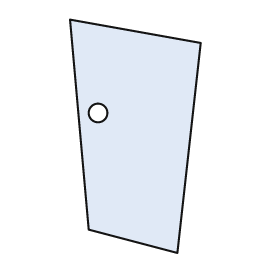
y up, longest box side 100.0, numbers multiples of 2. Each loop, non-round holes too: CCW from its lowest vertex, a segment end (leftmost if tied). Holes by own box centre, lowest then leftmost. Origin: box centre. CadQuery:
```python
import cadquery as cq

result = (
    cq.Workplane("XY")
    .moveTo(18.0, -50.0)
    .lineTo(28.0, 40.0)
    .lineTo(-28.0, 50.0)
    .lineTo(-20.0, -40.0)
    .close()
    .moveTo(-16.0, 10.0)
    .circle(4.0)
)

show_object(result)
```